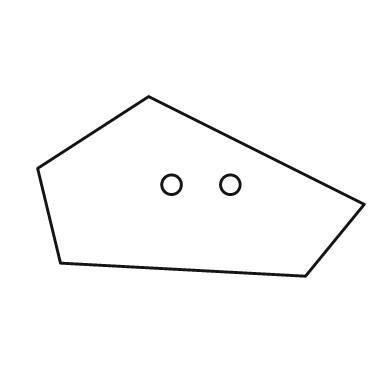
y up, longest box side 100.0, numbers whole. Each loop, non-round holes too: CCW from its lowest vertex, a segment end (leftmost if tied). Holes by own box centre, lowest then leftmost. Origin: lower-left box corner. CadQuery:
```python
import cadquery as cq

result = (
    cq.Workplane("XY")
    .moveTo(82.0, 0.0)
    .lineTo(100.0, 22.0)
    .lineTo(34.0, 55.0)
    .lineTo(0.0, 33.0)
    .lineTo(7.0, 4.0)
    .close()
    .moveTo(41.0, 28.0)
    .circle(3.0)
    .moveTo(59.0, 28.0)
    .circle(3.0)
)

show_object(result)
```